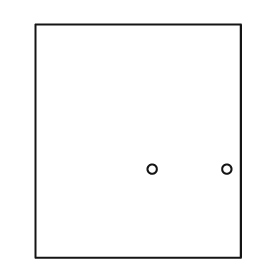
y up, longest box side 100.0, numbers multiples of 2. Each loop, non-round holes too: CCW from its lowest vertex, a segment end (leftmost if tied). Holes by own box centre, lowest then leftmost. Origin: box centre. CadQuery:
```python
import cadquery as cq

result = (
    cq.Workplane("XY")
    .moveTo(-44.0, -50.0)
    .lineTo(44.0, -50.0)
    .lineTo(44.0, 50.0)
    .lineTo(-44.0, 50.0)
    .close()
    .moveTo(6.0, -12.0)
    .circle(2.0)
    .moveTo(38.0, -12.0)
    .circle(2.0)
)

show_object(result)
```